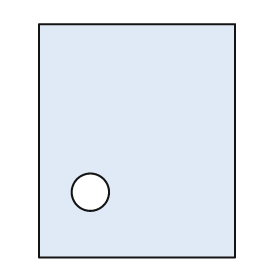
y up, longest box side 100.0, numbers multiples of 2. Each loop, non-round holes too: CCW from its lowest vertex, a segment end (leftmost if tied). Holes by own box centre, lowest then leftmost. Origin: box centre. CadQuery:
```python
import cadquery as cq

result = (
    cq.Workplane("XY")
    .moveTo(-42.0, -50.0)
    .lineTo(42.0, -50.0)
    .lineTo(42.0, 50.0)
    .lineTo(-42.0, 50.0)
    .close()
    .moveTo(-20.0, -22.0)
    .circle(8.0)
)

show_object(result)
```